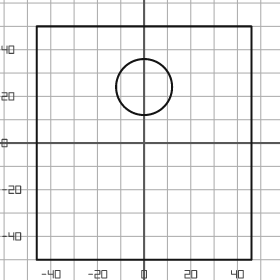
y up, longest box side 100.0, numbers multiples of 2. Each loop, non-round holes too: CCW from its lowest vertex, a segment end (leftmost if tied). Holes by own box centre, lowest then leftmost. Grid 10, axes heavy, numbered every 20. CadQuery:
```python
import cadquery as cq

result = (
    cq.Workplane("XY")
    .moveTo(-46.0, -50.0)
    .lineTo(46.0, -50.0)
    .lineTo(46.0, 50.0)
    .lineTo(-46.0, 50.0)
    .close()
    .moveTo(0.0, 24.0)
    .circle(12.0)
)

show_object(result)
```